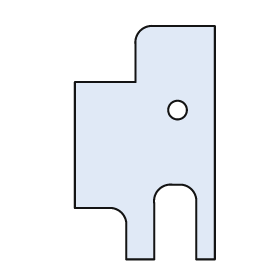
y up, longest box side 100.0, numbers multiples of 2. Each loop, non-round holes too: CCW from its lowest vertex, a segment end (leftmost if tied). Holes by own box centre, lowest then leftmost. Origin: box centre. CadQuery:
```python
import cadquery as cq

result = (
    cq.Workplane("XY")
    .moveTo(-8.0, -50.0)
    .lineTo(4.0, -50.0)
    .lineTo(4.0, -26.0)
    .threePointArc((6.0, -20.0), (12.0, -18.0))
    .lineTo(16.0, -18.0)
    .threePointArc((20.0, -20.0), (22.0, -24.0))
    .lineTo(22.0, -50.0)
    .lineTo(30.0, -50.0)
    .lineTo(30.0, 50.0)
    .lineTo(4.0, 50.0)
    .threePointArc((-2.0, 48.0), (-4.0, 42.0))
    .lineTo(-4.0, 26.0)
    .lineTo(-30.0, 26.0)
    .lineTo(-30.0, -28.0)
    .lineTo(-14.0, -28.0)
    .threePointArc((-10.0, -30.0), (-8.0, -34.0))
    .close()
    .moveTo(14.0, 14.0)
    .circle(4.0)
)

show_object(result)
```